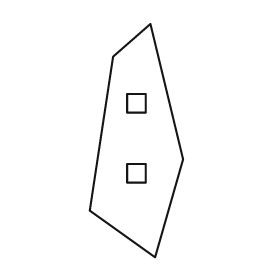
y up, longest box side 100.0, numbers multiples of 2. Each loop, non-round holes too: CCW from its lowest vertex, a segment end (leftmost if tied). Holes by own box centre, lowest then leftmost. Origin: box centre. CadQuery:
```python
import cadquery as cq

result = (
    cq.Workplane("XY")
    .moveTo(8.0, -50.0)
    .lineTo(20.0, -8.0)
    .lineTo(6.0, 50.0)
    .lineTo(-10.0, 36.0)
    .lineTo(-20.0, -30.0)
    .close()
    .moveTo(-4.0, -18.0)
    .lineTo(4.0, -18.0)
    .lineTo(4.0, -10.0)
    .lineTo(-4.0, -10.0)
    .close()
    .moveTo(-4.0, 12.0)
    .lineTo(4.0, 12.0)
    .lineTo(4.0, 20.0)
    .lineTo(-4.0, 20.0)
    .close()
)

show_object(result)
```